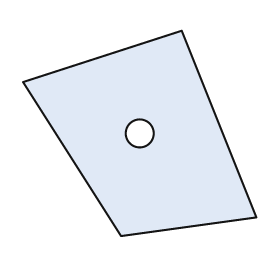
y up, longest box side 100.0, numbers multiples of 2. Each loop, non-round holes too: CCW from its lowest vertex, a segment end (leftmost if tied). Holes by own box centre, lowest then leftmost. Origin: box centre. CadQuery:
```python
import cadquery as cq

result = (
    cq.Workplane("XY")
    .moveTo(-8.0, -44.0)
    .lineTo(50.0, -36.0)
    .lineTo(18.0, 44.0)
    .lineTo(-50.0, 22.0)
    .close()
    .moveTo(0.0, 0.0)
    .circle(6.0)
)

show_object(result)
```